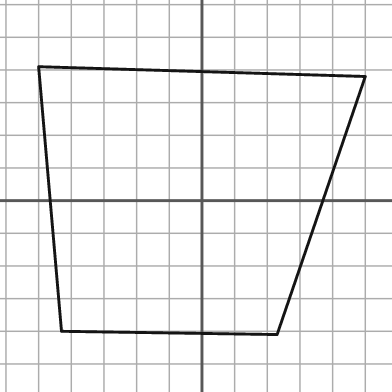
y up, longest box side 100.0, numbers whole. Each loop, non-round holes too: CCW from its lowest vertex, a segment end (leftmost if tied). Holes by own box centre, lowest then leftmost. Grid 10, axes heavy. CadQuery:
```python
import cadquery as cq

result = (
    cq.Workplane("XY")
    .moveTo(23.0, -41.0)
    .lineTo(50.0, 38.0)
    .lineTo(-50.0, 41.0)
    .lineTo(-43.0, -40.0)
    .close()
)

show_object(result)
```